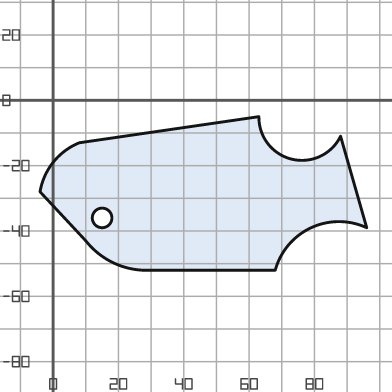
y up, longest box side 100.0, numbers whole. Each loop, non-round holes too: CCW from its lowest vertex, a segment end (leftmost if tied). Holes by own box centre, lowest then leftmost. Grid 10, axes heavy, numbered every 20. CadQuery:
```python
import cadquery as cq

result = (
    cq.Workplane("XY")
    .moveTo(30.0, -52.0)
    .lineTo(68.0, -52.0)
    .threePointArc((79.0, -39.0), (96.0, -39.0))
    .lineTo(88.0, -11.0)
    .threePointArc((73.0, -18.0), (63.0, -5.0))
    .lineTo(8.0, -13.0)
    .threePointArc((0.0, -19.0), (-4.0, -28.0))
    .lineTo(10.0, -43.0)
    .threePointArc((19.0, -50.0), (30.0, -52.0))
    .close()
    .moveTo(15.0, -36.0)
    .circle(3.0)
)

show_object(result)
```